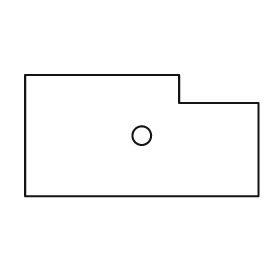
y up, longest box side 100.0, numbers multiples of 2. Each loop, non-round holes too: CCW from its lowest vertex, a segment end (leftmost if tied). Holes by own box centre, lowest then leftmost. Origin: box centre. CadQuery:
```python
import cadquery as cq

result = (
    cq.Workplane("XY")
    .moveTo(-50.0, -26.0)
    .lineTo(50.0, -26.0)
    .lineTo(50.0, 14.0)
    .lineTo(16.0, 14.0)
    .lineTo(16.0, 26.0)
    .lineTo(-50.0, 26.0)
    .close()
    .moveTo(0.0, 0.0)
    .circle(4.0)
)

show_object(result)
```